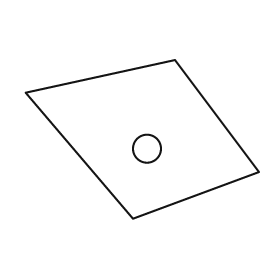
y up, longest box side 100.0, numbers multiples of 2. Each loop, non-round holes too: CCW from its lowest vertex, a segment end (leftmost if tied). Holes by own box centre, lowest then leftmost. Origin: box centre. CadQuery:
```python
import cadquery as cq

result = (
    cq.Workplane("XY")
    .moveTo(-4.0, -34.0)
    .lineTo(50.0, -14.0)
    .lineTo(14.0, 34.0)
    .lineTo(-50.0, 20.0)
    .close()
    .moveTo(2.0, -4.0)
    .circle(6.0)
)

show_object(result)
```